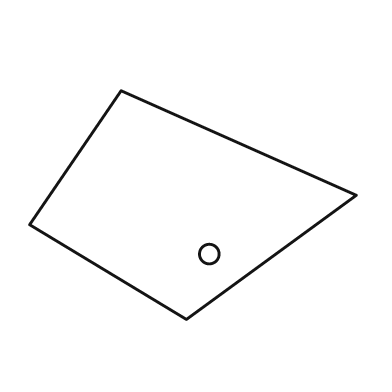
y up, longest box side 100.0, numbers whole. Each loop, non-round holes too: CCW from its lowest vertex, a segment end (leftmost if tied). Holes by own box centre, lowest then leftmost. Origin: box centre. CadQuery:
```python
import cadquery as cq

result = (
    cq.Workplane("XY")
    .moveTo(-2.0, -35.0)
    .lineTo(50.0, 3.0)
    .lineTo(-22.0, 35.0)
    .lineTo(-50.0, -6.0)
    .close()
    .moveTo(5.0, -15.0)
    .circle(3.0)
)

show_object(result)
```